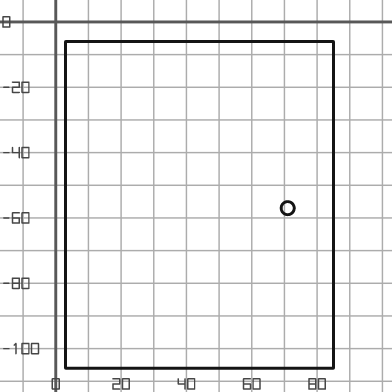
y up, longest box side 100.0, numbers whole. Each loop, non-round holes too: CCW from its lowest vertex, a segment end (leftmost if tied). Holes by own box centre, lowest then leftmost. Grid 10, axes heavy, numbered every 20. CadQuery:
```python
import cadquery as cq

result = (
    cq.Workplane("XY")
    .moveTo(3.0, -106.0)
    .lineTo(85.0, -106.0)
    .lineTo(85.0, -6.0)
    .lineTo(3.0, -6.0)
    .close()
    .moveTo(71.0, -57.0)
    .circle(2.0)
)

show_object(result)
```